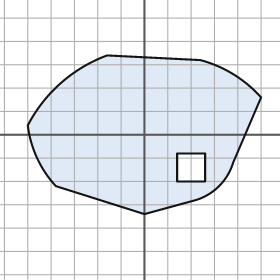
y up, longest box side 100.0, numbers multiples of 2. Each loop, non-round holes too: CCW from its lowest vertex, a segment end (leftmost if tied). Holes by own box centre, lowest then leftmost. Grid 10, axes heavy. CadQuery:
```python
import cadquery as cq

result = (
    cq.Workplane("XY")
    .moveTo(0.0, -34.0)
    .lineTo(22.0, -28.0)
    .threePointArc((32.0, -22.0), (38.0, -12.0))
    .lineTo(50.0, 16.0)
    .threePointArc((38.0, 26.0), (24.0, 32.0))
    .lineTo(-16.0, 34.0)
    .threePointArc((-36.0, 22.0), (-50.0, 4.0))
    .threePointArc((-46.0, -10.0), (-38.0, -22.0))
    .close()
    .moveTo(14.0, -20.0)
    .lineTo(26.0, -20.0)
    .lineTo(26.0, -8.0)
    .lineTo(14.0, -8.0)
    .close()
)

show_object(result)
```